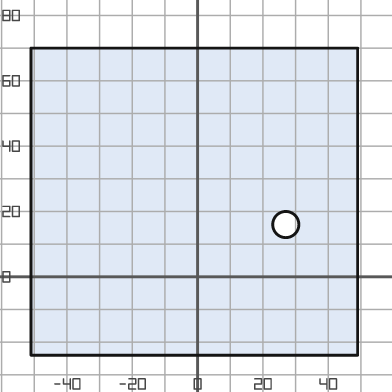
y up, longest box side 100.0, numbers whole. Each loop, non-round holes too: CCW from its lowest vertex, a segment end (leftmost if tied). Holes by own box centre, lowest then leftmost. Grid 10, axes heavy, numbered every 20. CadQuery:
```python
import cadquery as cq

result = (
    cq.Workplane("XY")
    .moveTo(-51.0, -24.0)
    .lineTo(49.0, -24.0)
    .lineTo(49.0, 70.0)
    .lineTo(-51.0, 70.0)
    .close()
    .moveTo(27.0, 16.0)
    .circle(4.0)
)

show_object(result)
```